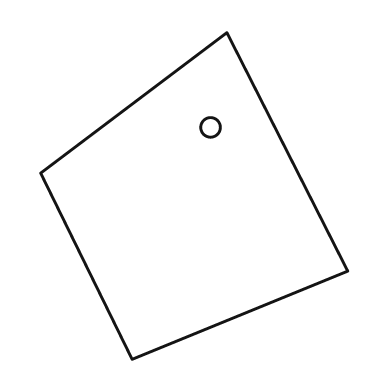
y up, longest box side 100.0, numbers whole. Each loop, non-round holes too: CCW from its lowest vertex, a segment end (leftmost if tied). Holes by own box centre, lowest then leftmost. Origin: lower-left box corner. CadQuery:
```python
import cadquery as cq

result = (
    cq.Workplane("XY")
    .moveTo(28.0, 0.0)
    .lineTo(94.0, 27.0)
    .lineTo(57.0, 100.0)
    .lineTo(0.0, 57.0)
    .close()
    .moveTo(52.0, 71.0)
    .circle(3.0)
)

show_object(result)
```